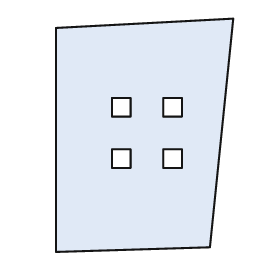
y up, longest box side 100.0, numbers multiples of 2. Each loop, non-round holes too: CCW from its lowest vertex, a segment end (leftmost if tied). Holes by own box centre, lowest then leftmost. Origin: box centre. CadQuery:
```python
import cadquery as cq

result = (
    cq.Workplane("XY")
    .moveTo(-38.0, -50.0)
    .lineTo(28.0, -48.0)
    .lineTo(38.0, 50.0)
    .lineTo(-38.0, 46.0)
    .close()
    .moveTo(-14.0, -14.0)
    .lineTo(-6.0, -14.0)
    .lineTo(-6.0, -6.0)
    .lineTo(-14.0, -6.0)
    .close()
    .moveTo(8.0, -14.0)
    .lineTo(16.0, -14.0)
    .lineTo(16.0, -6.0)
    .lineTo(8.0, -6.0)
    .close()
    .moveTo(-14.0, 8.0)
    .lineTo(-6.0, 8.0)
    .lineTo(-6.0, 16.0)
    .lineTo(-14.0, 16.0)
    .close()
    .moveTo(8.0, 8.0)
    .lineTo(16.0, 8.0)
    .lineTo(16.0, 16.0)
    .lineTo(8.0, 16.0)
    .close()
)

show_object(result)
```